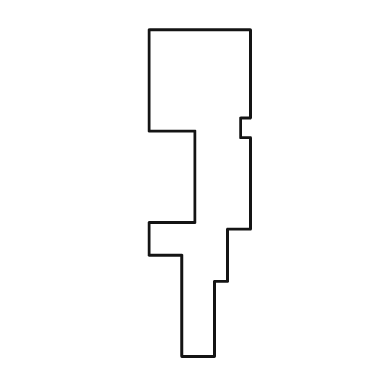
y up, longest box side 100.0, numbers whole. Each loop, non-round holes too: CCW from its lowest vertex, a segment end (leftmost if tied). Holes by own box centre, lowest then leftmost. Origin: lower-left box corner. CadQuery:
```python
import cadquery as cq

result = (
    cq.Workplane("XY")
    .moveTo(10.0, 0.0)
    .lineTo(20.0, 0.0)
    .lineTo(20.0, 23.0)
    .lineTo(24.0, 23.0)
    .lineTo(24.0, 39.0)
    .lineTo(31.0, 39.0)
    .lineTo(31.0, 67.0)
    .lineTo(28.0, 67.0)
    .lineTo(28.0, 73.0)
    .lineTo(31.0, 73.0)
    .lineTo(31.0, 100.0)
    .lineTo(0.0, 100.0)
    .lineTo(0.0, 69.0)
    .lineTo(14.0, 69.0)
    .lineTo(14.0, 41.0)
    .lineTo(0.0, 41.0)
    .lineTo(0.0, 31.0)
    .lineTo(10.0, 31.0)
    .close()
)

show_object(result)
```